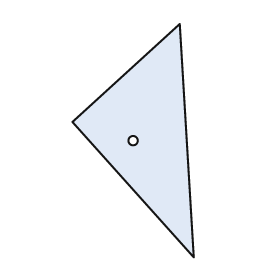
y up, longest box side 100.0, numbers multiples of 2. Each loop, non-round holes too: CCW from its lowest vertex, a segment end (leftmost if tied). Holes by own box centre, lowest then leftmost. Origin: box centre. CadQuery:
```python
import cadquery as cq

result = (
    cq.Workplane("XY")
    .moveTo(26.0, -50.0)
    .lineTo(20.0, 50.0)
    .lineTo(-26.0, 8.0)
    .close()
    .moveTo(0.0, 0.0)
    .circle(2.0)
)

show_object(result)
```